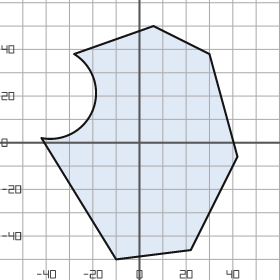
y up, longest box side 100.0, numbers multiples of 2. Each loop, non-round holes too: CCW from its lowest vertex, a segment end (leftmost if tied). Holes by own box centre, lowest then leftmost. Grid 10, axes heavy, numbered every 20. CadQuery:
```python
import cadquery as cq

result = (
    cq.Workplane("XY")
    .moveTo(-10.0, -50.0)
    .lineTo(22.0, -46.0)
    .lineTo(42.0, -6.0)
    .lineTo(30.0, 38.0)
    .lineTo(6.0, 50.0)
    .lineTo(-28.0, 38.0)
    .threePointArc((-20.0, 14.0), (-42.0, 2.0))
    .close()
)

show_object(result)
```